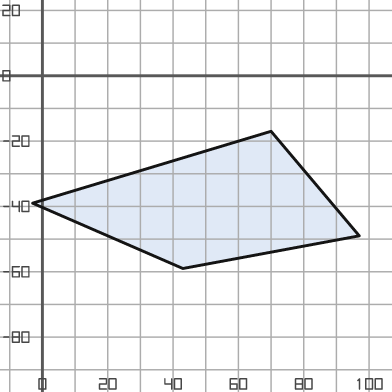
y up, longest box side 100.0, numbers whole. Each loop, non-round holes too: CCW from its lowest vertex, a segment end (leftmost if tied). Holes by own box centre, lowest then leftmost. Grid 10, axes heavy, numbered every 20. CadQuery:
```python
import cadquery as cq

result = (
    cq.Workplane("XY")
    .moveTo(43.0, -59.0)
    .lineTo(97.0, -49.0)
    .lineTo(70.0, -17.0)
    .lineTo(-3.0, -39.0)
    .close()
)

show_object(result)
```